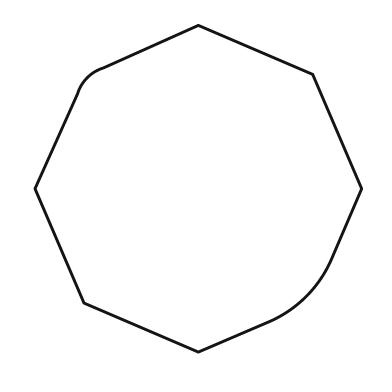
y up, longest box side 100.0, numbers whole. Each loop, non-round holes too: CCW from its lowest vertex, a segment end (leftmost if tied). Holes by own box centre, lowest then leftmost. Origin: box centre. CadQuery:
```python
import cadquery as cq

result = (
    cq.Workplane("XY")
    .moveTo(0.0, -50.0)
    .lineTo(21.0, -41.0)
    .threePointArc((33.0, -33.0), (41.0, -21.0))
    .lineTo(50.0, 0.0)
    .lineTo(35.0, 35.0)
    .lineTo(0.0, 50.0)
    .lineTo(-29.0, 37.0)
    .threePointArc((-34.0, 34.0), (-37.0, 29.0))
    .lineTo(-50.0, 0.0)
    .lineTo(-35.0, -35.0)
    .close()
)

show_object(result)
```